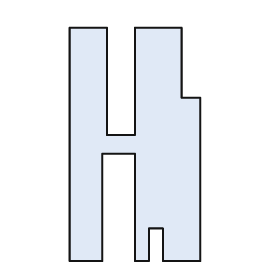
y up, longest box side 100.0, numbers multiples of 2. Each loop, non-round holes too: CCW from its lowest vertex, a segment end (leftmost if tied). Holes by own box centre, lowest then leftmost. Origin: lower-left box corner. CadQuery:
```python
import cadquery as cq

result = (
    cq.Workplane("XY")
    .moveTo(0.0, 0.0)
    .lineTo(14.0, 0.0)
    .lineTo(14.0, 46.0)
    .lineTo(28.0, 46.0)
    .lineTo(28.0, 0.0)
    .lineTo(34.0, 0.0)
    .lineTo(34.0, 14.0)
    .lineTo(40.0, 14.0)
    .lineTo(40.0, 0.0)
    .lineTo(56.0, 0.0)
    .lineTo(56.0, 70.0)
    .lineTo(48.0, 70.0)
    .lineTo(48.0, 100.0)
    .lineTo(28.0, 100.0)
    .lineTo(28.0, 54.0)
    .lineTo(16.0, 54.0)
    .lineTo(16.0, 100.0)
    .lineTo(0.0, 100.0)
    .close()
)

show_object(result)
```